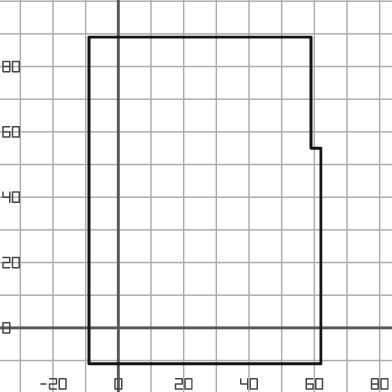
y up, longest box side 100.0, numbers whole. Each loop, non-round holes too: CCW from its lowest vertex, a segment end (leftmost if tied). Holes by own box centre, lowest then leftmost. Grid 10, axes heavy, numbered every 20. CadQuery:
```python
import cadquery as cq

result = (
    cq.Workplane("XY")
    .moveTo(-9.0, -11.0)
    .lineTo(62.0, -11.0)
    .lineTo(62.0, 55.0)
    .lineTo(59.0, 55.0)
    .lineTo(59.0, 89.0)
    .lineTo(-9.0, 89.0)
    .close()
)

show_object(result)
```